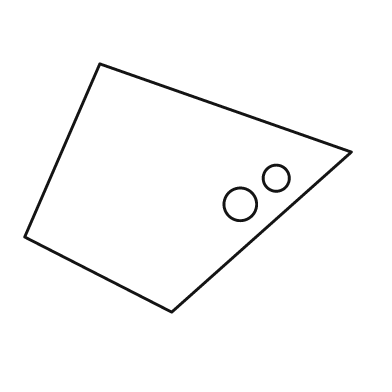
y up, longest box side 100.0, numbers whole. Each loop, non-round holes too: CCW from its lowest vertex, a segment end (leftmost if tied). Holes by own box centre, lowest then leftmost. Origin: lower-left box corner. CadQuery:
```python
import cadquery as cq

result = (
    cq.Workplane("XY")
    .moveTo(45.0, 0.0)
    .lineTo(100.0, 49.0)
    .lineTo(23.0, 76.0)
    .lineTo(0.0, 23.0)
    .close()
    .moveTo(66.0, 33.0)
    .circle(5.0)
    .moveTo(77.0, 41.0)
    .circle(4.0)
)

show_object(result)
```